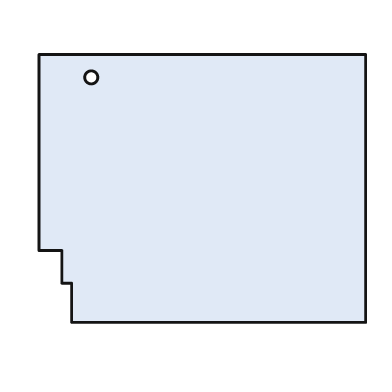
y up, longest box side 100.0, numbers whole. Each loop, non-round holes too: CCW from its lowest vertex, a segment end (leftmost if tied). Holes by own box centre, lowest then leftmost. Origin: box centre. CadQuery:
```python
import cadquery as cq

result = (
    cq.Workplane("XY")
    .moveTo(-40.0, -41.0)
    .lineTo(50.0, -41.0)
    .lineTo(50.0, 41.0)
    .lineTo(-50.0, 41.0)
    .lineTo(-50.0, -19.0)
    .lineTo(-43.0, -19.0)
    .lineTo(-43.0, -29.0)
    .lineTo(-40.0, -29.0)
    .close()
    .moveTo(-34.0, 34.0)
    .circle(2.0)
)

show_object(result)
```